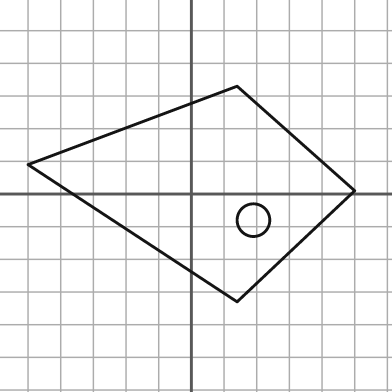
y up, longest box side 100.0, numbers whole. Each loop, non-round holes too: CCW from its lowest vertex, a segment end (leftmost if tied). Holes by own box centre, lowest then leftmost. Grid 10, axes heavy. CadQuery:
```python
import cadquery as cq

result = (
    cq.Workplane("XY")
    .moveTo(14.0, -33.0)
    .lineTo(50.0, 1.0)
    .lineTo(14.0, 33.0)
    .lineTo(-50.0, 9.0)
    .close()
    .moveTo(19.0, -8.0)
    .circle(5.0)
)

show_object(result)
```